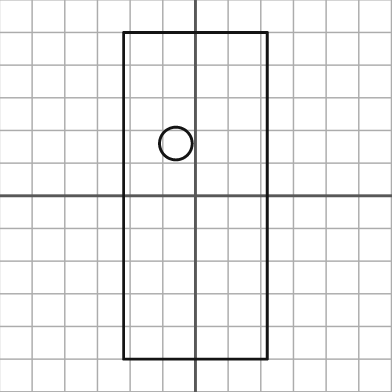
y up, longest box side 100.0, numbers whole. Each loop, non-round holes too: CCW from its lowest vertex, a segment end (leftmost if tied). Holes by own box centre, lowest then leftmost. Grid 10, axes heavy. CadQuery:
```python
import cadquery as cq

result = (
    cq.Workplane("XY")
    .moveTo(-22.0, -50.0)
    .lineTo(22.0, -50.0)
    .lineTo(22.0, 50.0)
    .lineTo(-22.0, 50.0)
    .close()
    .moveTo(-6.0, 16.0)
    .circle(5.0)
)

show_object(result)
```